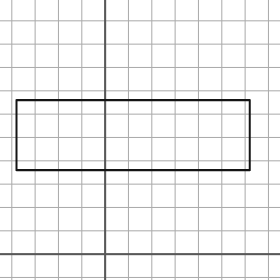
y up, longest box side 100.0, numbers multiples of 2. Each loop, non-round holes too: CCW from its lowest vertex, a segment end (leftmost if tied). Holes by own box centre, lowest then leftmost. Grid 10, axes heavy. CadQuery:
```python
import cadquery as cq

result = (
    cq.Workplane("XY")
    .moveTo(-38.0, 36.0)
    .lineTo(62.0, 36.0)
    .lineTo(62.0, 66.0)
    .lineTo(-38.0, 66.0)
    .close()
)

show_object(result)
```